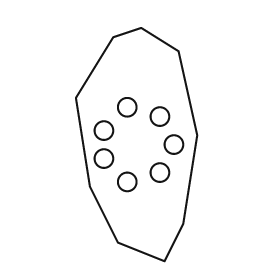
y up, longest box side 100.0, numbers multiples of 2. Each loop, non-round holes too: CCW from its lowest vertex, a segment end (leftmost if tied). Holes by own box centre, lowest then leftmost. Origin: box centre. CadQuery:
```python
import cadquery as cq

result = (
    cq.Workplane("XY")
    .moveTo(12.0, -50.0)
    .lineTo(20.0, -34.0)
    .lineTo(26.0, 4.0)
    .lineTo(18.0, 40.0)
    .lineTo(2.0, 50.0)
    .lineTo(-10.0, 46.0)
    .lineTo(-26.0, 20.0)
    .lineTo(-20.0, -18.0)
    .lineTo(-8.0, -42.0)
    .close()
    .moveTo(-4.0, -16.0)
    .circle(4.0)
    .moveTo(10.0, -12.0)
    .circle(4.0)
    .moveTo(-14.0, -6.0)
    .circle(4.0)
    .moveTo(16.0, 0.0)
    .circle(4.0)
    .moveTo(-14.0, 6.0)
    .circle(4.0)
    .moveTo(10.0, 12.0)
    .circle(4.0)
    .moveTo(-4.0, 16.0)
    .circle(4.0)
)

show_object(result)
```